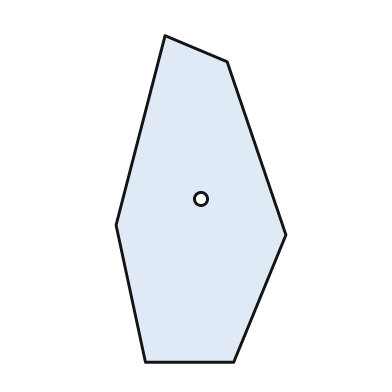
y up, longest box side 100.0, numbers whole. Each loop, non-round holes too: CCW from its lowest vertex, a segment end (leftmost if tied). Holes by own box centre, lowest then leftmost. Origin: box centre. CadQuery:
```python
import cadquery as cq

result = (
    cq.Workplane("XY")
    .moveTo(-17.0, -50.0)
    .lineTo(10.0, -50.0)
    .lineTo(26.0, -11.0)
    .lineTo(8.0, 42.0)
    .lineTo(-11.0, 50.0)
    .lineTo(-26.0, -8.0)
    .close()
    .moveTo(0.0, 0.0)
    .circle(2.0)
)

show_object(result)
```